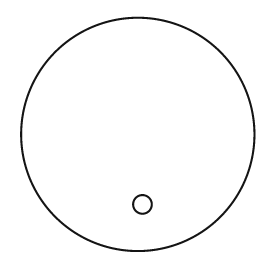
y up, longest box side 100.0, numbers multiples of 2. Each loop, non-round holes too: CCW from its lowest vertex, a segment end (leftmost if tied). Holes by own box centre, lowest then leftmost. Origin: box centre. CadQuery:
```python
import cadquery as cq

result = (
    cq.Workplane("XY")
    .moveTo(0.0, 0.0)
    .circle(50.0)
    .moveTo(2.0, -30.0)
    .circle(4.0)
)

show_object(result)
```